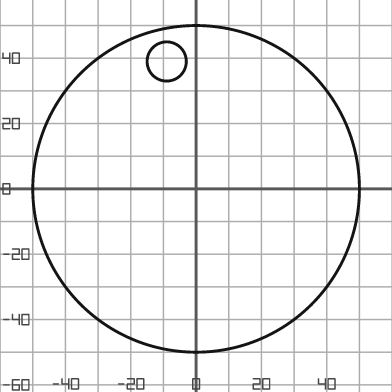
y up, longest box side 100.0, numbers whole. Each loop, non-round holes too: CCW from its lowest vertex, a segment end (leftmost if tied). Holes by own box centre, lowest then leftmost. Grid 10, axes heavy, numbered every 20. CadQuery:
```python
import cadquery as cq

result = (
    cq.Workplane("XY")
    .moveTo(0.0, 0.0)
    .circle(50.0)
    .moveTo(-9.0, 39.0)
    .circle(6.0)
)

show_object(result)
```